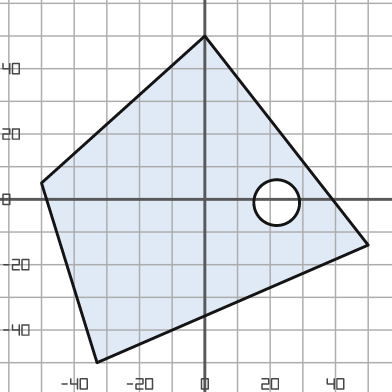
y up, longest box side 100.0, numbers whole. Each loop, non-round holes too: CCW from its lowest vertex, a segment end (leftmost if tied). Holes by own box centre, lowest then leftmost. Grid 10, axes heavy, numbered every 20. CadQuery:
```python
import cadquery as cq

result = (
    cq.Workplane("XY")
    .moveTo(-33.0, -50.0)
    .lineTo(50.0, -14.0)
    .lineTo(0.0, 50.0)
    .lineTo(-50.0, 5.0)
    .close()
    .moveTo(22.0, -1.0)
    .circle(7.0)
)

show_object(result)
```